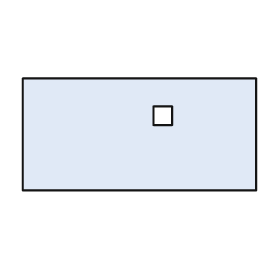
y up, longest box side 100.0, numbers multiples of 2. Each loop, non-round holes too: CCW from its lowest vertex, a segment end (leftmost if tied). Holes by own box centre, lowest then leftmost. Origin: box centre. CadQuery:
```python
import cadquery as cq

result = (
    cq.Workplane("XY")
    .moveTo(-50.0, -24.0)
    .lineTo(50.0, -24.0)
    .lineTo(50.0, 24.0)
    .lineTo(-50.0, 24.0)
    .close()
    .moveTo(6.0, 4.0)
    .lineTo(14.0, 4.0)
    .lineTo(14.0, 12.0)
    .lineTo(6.0, 12.0)
    .close()
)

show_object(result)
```